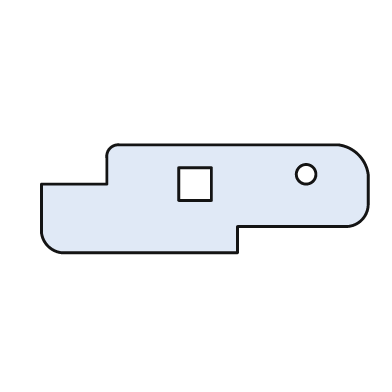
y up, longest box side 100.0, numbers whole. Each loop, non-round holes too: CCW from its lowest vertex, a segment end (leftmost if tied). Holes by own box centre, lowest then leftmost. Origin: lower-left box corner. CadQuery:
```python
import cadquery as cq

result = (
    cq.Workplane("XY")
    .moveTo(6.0, 0.0)
    .lineTo(60.0, 0.0)
    .lineTo(60.0, 8.0)
    .lineTo(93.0, 8.0)
    .threePointArc((98.0, 10.0), (100.0, 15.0))
    .lineTo(100.0, 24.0)
    .threePointArc((97.0, 30.0), (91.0, 33.0))
    .lineTo(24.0, 33.0)
    .threePointArc((21.0, 32.0), (20.0, 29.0))
    .lineTo(20.0, 21.0)
    .lineTo(0.0, 21.0)
    .lineTo(0.0, 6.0)
    .threePointArc((2.0, 2.0), (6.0, 0.0))
    .close()
    .moveTo(42.0, 16.0)
    .lineTo(52.0, 16.0)
    .lineTo(52.0, 26.0)
    .lineTo(42.0, 26.0)
    .close()
    .moveTo(81.0, 24.0)
    .circle(3.0)
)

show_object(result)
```